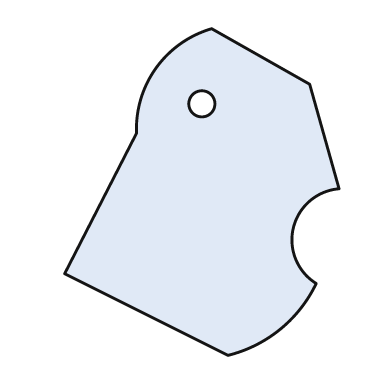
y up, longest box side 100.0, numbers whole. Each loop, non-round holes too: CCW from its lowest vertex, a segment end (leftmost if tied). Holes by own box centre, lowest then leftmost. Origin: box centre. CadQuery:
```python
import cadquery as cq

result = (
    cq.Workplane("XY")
    .moveTo(8.0, -50.0)
    .threePointArc((24.0, -42.0), (35.0, -28.0))
    .threePointArc((28.0, -11.0), (42.0, 1.0))
    .lineTo(33.0, 33.0)
    .lineTo(3.0, 50.0)
    .threePointArc((-14.0, 38.0), (-20.0, 18.0))
    .lineTo(-42.0, -25.0)
    .close()
    .moveTo(0.0, 27.0)
    .circle(4.0)
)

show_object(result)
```